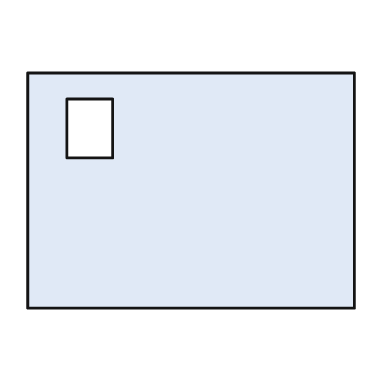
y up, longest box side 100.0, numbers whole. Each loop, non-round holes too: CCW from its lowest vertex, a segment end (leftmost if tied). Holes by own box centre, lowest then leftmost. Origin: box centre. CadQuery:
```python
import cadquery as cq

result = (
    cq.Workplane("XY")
    .moveTo(-50.0, -36.0)
    .lineTo(50.0, -36.0)
    .lineTo(50.0, 36.0)
    .lineTo(-50.0, 36.0)
    .close()
    .moveTo(-38.0, 10.0)
    .lineTo(-24.0, 10.0)
    .lineTo(-24.0, 28.0)
    .lineTo(-38.0, 28.0)
    .close()
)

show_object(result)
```